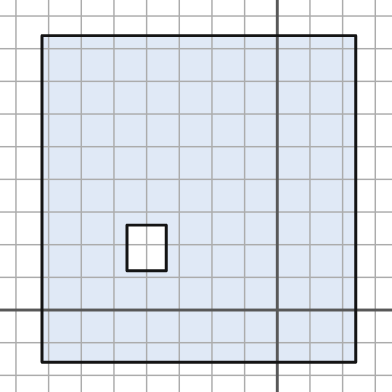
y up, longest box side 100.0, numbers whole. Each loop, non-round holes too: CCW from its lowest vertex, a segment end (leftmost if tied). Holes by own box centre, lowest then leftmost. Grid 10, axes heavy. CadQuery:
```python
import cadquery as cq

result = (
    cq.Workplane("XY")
    .moveTo(-72.0, -16.0)
    .lineTo(24.0, -16.0)
    .lineTo(24.0, 84.0)
    .lineTo(-72.0, 84.0)
    .close()
    .moveTo(-46.0, 12.0)
    .lineTo(-34.0, 12.0)
    .lineTo(-34.0, 26.0)
    .lineTo(-46.0, 26.0)
    .close()
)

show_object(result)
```